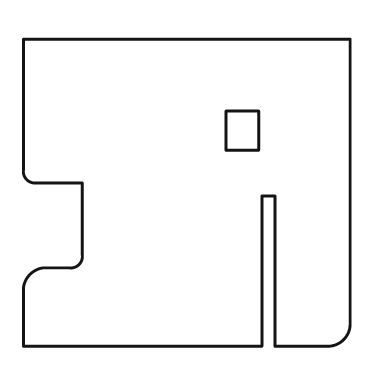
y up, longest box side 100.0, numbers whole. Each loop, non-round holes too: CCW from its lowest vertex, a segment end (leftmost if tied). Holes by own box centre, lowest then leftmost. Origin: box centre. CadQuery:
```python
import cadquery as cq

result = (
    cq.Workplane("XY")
    .moveTo(-50.0, -47.0)
    .lineTo(23.0, -47.0)
    .lineTo(23.0, -1.0)
    .lineTo(27.0, -1.0)
    .lineTo(27.0, -47.0)
    .lineTo(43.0, -47.0)
    .threePointArc((48.0, -45.0), (50.0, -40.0))
    .lineTo(50.0, 47.0)
    .lineTo(-50.0, 47.0)
    .lineTo(-50.0, 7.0)
    .threePointArc((-49.0, 4.0), (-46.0, 3.0))
    .lineTo(-32.0, 3.0)
    .lineTo(-32.0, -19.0)
    .threePointArc((-33.0, -22.0), (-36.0, -23.0))
    .lineTo(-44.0, -23.0)
    .threePointArc((-48.0, -25.0), (-50.0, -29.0))
    .close()
    .moveTo(12.0, 13.0)
    .lineTo(22.0, 13.0)
    .lineTo(22.0, 25.0)
    .lineTo(12.0, 25.0)
    .close()
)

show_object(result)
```